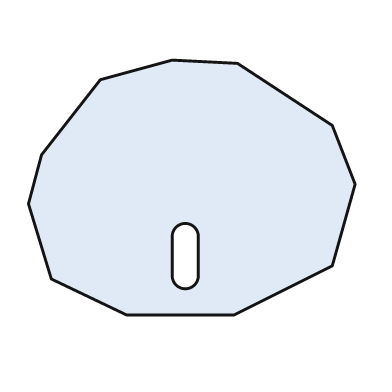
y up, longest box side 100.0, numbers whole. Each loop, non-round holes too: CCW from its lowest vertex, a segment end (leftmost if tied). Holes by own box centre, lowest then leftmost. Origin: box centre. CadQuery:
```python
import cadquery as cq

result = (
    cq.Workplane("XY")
    .moveTo(-20.0, -39.0)
    .lineTo(13.0, -39.0)
    .lineTo(43.0, -24.0)
    .lineTo(50.0, 1.0)
    .lineTo(43.0, 19.0)
    .lineTo(14.0, 38.0)
    .lineTo(-6.0, 39.0)
    .lineTo(-28.0, 33.0)
    .lineTo(-46.0, 10.0)
    .lineTo(-50.0, -5.0)
    .lineTo(-43.0, -28.0)
    .close()
    .moveTo(-6.0, -27.0)
    .threePointArc((-2.0, -31.0), (2.0, -27.0))
    .lineTo(2.0, -15.0)
    .threePointArc((-2.0, -11.0), (-6.0, -15.0))
    .close()
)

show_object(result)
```